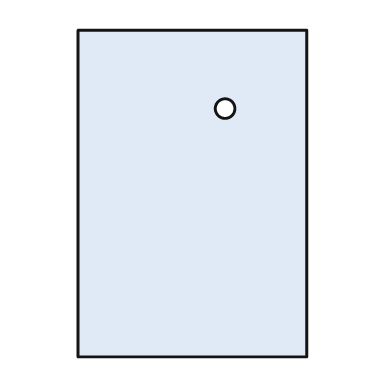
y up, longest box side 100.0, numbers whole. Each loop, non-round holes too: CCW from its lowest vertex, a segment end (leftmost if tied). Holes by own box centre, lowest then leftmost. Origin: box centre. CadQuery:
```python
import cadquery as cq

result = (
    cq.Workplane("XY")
    .moveTo(-35.0, -50.0)
    .lineTo(35.0, -50.0)
    .lineTo(35.0, 50.0)
    .lineTo(-35.0, 50.0)
    .close()
    .moveTo(10.0, 26.0)
    .circle(3.0)
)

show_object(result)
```